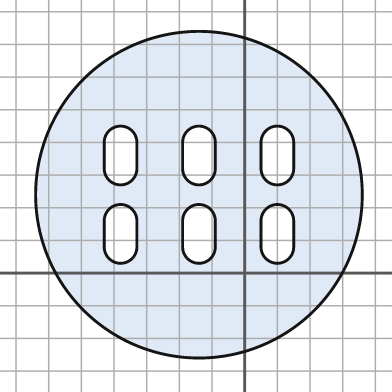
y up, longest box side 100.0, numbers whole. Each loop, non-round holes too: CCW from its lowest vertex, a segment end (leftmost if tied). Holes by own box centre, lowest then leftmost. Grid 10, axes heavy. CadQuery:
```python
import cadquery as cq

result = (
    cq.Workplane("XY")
    .moveTo(-14.0, 24.0)
    .circle(50.0)
    .moveTo(-43.0, 8.0)
    .threePointArc((-38.0, 3.0), (-33.0, 8.0))
    .lineTo(-33.0, 16.0)
    .threePointArc((-38.0, 21.0), (-43.0, 16.0))
    .close()
    .moveTo(-19.0, 8.0)
    .threePointArc((-14.0, 3.0), (-9.0, 8.0))
    .lineTo(-9.0, 16.0)
    .threePointArc((-14.0, 21.0), (-19.0, 16.0))
    .close()
    .moveTo(5.0, 8.0)
    .threePointArc((10.0, 3.0), (15.0, 8.0))
    .lineTo(15.0, 16.0)
    .threePointArc((10.0, 21.0), (5.0, 16.0))
    .close()
    .moveTo(-43.0, 32.0)
    .threePointArc((-38.0, 27.0), (-33.0, 32.0))
    .lineTo(-33.0, 40.0)
    .threePointArc((-38.0, 45.0), (-43.0, 40.0))
    .close()
    .moveTo(-19.0, 32.0)
    .threePointArc((-14.0, 27.0), (-9.0, 32.0))
    .lineTo(-9.0, 40.0)
    .threePointArc((-14.0, 45.0), (-19.0, 40.0))
    .close()
    .moveTo(5.0, 32.0)
    .threePointArc((10.0, 27.0), (15.0, 32.0))
    .lineTo(15.0, 40.0)
    .threePointArc((10.0, 45.0), (5.0, 40.0))
    .close()
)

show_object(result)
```